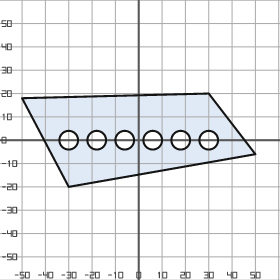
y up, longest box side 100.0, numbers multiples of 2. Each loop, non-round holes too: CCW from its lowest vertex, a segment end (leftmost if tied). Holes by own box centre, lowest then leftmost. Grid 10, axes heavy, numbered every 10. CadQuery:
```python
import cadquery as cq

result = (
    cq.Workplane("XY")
    .moveTo(-30.0, -20.0)
    .lineTo(50.0, -6.0)
    .lineTo(30.0, 20.0)
    .lineTo(-50.0, 18.0)
    .close()
    .moveTo(-30.0, 0.0)
    .circle(4.0)
    .moveTo(-18.0, 0.0)
    .circle(4.0)
    .moveTo(-6.0, 0.0)
    .circle(4.0)
    .moveTo(6.0, 0.0)
    .circle(4.0)
    .moveTo(18.0, 0.0)
    .circle(4.0)
    .moveTo(30.0, 0.0)
    .circle(4.0)
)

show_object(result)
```